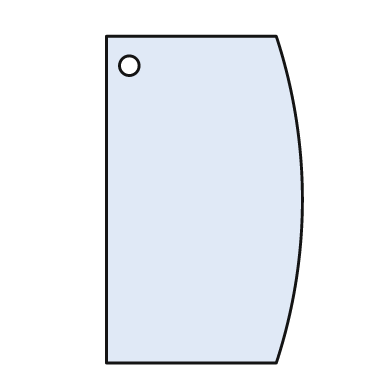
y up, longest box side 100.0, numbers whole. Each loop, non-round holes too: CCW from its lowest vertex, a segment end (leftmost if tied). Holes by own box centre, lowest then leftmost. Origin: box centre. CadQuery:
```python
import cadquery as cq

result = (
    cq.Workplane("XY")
    .moveTo(-30.0, -50.0)
    .lineTo(22.0, -50.0)
    .threePointArc((30.0, 0.0), (22.0, 50.0))
    .lineTo(-30.0, 50.0)
    .close()
    .moveTo(-23.0, 41.0)
    .circle(3.0)
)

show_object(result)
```